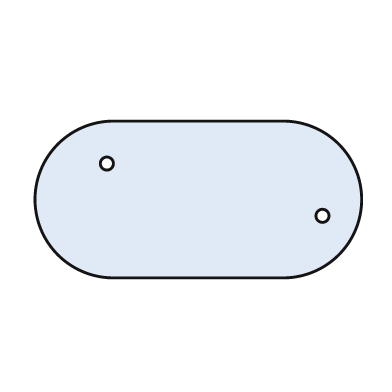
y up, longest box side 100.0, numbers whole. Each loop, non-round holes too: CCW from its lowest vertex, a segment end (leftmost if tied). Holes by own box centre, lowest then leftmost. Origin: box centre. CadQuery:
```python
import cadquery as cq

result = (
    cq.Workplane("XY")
    .moveTo(-26.0, -24.0)
    .lineTo(26.0, -24.0)
    .threePointArc((50.0, 0.0), (26.0, 24.0))
    .lineTo(-26.0, 24.0)
    .threePointArc((-50.0, 0.0), (-26.0, -24.0))
    .close()
    .moveTo(38.0, -5.0)
    .circle(2.0)
    .moveTo(-28.0, 11.0)
    .circle(2.0)
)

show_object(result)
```